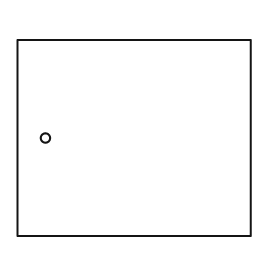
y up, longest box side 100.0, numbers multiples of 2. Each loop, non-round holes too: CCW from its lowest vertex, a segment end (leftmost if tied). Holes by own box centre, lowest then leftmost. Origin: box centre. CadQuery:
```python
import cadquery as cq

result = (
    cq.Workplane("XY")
    .moveTo(-50.0, -42.0)
    .lineTo(50.0, -42.0)
    .lineTo(50.0, 42.0)
    .lineTo(-50.0, 42.0)
    .close()
    .moveTo(-38.0, 0.0)
    .circle(2.0)
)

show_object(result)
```